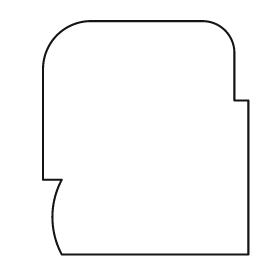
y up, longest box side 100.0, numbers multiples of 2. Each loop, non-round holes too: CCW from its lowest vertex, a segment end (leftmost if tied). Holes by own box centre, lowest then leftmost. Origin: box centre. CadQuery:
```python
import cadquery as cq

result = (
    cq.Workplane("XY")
    .moveTo(-36.0, -50.0)
    .lineTo(44.0, -50.0)
    .lineTo(44.0, 16.0)
    .lineTo(38.0, 16.0)
    .lineTo(38.0, 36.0)
    .threePointArc((34.0, 46.0), (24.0, 50.0))
    .lineTo(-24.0, 50.0)
    .threePointArc((-38.0, 44.0), (-44.0, 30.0))
    .lineTo(-44.0, -18.0)
    .lineTo(-36.0, -18.0)
    .threePointArc((-40.0, -34.0), (-36.0, -50.0))
    .close()
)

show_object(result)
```